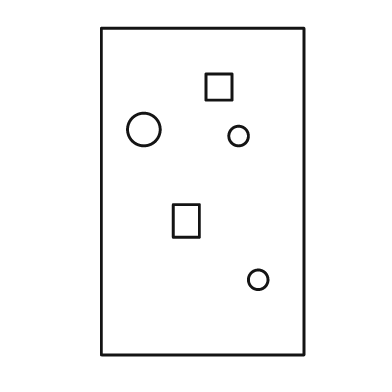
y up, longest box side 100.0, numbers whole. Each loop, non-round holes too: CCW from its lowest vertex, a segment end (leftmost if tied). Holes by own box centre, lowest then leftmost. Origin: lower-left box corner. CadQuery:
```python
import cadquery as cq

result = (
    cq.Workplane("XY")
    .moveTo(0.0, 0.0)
    .lineTo(62.0, 0.0)
    .lineTo(62.0, 100.0)
    .lineTo(0.0, 100.0)
    .close()
    .moveTo(48.0, 23.0)
    .circle(3.0)
    .moveTo(22.0, 36.0)
    .lineTo(30.0, 36.0)
    .lineTo(30.0, 46.0)
    .lineTo(22.0, 46.0)
    .close()
    .moveTo(42.0, 67.0)
    .circle(3.0)
    .moveTo(13.0, 69.0)
    .circle(5.0)
    .moveTo(32.0, 78.0)
    .lineTo(40.0, 78.0)
    .lineTo(40.0, 86.0)
    .lineTo(32.0, 86.0)
    .close()
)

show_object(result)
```